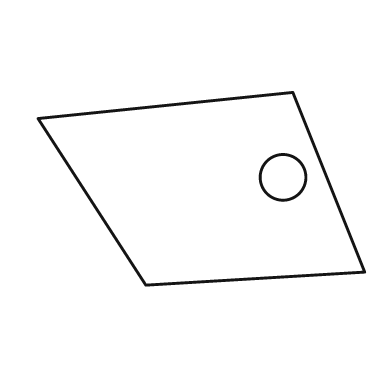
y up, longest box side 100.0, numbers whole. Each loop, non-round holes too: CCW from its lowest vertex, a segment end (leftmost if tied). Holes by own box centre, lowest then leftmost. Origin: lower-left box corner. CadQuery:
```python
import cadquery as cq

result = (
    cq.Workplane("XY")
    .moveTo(33.0, 0.0)
    .lineTo(100.0, 4.0)
    .lineTo(78.0, 59.0)
    .lineTo(0.0, 51.0)
    .close()
    .moveTo(75.0, 33.0)
    .circle(7.0)
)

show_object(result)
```